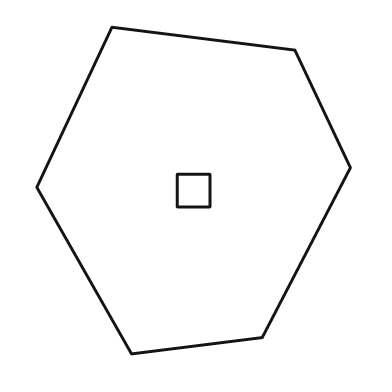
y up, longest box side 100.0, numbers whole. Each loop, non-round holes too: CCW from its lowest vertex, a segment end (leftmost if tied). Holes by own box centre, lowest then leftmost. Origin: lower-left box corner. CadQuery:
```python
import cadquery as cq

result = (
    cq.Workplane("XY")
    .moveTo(29.0, 0.0)
    .lineTo(69.0, 5.0)
    .lineTo(96.0, 57.0)
    .lineTo(79.0, 93.0)
    .lineTo(23.0, 100.0)
    .lineTo(0.0, 51.0)
    .close()
    .moveTo(43.0, 45.0)
    .lineTo(53.0, 45.0)
    .lineTo(53.0, 55.0)
    .lineTo(43.0, 55.0)
    .close()
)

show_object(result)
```